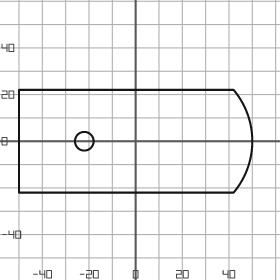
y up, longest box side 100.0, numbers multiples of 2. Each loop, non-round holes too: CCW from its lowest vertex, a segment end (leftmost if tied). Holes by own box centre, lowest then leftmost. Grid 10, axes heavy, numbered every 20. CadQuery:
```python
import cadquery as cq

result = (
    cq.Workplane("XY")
    .moveTo(-50.0, -22.0)
    .lineTo(42.0, -22.0)
    .threePointArc((50.0, 0.0), (42.0, 22.0))
    .lineTo(-50.0, 22.0)
    .close()
    .moveTo(-22.0, 0.0)
    .circle(4.0)
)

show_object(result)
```